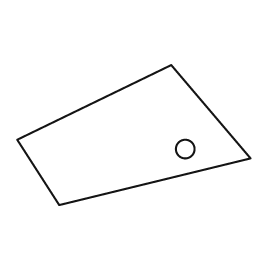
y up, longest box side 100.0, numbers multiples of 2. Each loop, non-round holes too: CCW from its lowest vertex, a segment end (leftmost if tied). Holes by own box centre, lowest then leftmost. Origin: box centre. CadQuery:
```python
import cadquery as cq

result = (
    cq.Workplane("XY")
    .moveTo(-32.0, -30.0)
    .lineTo(50.0, -10.0)
    .lineTo(16.0, 30.0)
    .lineTo(-50.0, -2.0)
    .close()
    .moveTo(22.0, -6.0)
    .circle(4.0)
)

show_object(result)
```